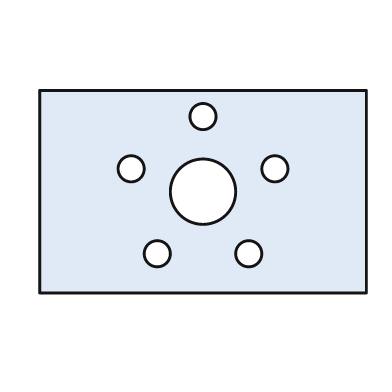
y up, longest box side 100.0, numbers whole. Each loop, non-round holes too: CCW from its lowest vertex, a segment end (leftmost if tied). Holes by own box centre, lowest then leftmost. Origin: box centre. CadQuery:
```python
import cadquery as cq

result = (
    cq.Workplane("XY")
    .moveTo(-50.0, -31.0)
    .lineTo(50.0, -31.0)
    .lineTo(50.0, 31.0)
    .lineTo(-50.0, 31.0)
    .close()
    .moveTo(-14.0, -19.0)
    .circle(4.0)
    .moveTo(14.0, -19.0)
    .circle(4.0)
    .moveTo(0.0, 0.0)
    .circle(10.0)
    .moveTo(-22.0, 7.0)
    .circle(4.0)
    .moveTo(22.0, 7.0)
    .circle(4.0)
    .moveTo(0.0, 23.0)
    .circle(4.0)
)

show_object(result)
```